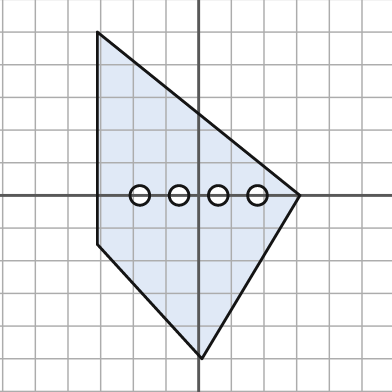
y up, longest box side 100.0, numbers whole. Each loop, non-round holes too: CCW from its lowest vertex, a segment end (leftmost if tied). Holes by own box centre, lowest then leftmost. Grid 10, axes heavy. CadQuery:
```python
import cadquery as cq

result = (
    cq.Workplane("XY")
    .moveTo(1.0, -50.0)
    .lineTo(31.0, 0.0)
    .lineTo(-31.0, 50.0)
    .lineTo(-31.0, -15.0)
    .close()
    .moveTo(-18.0, 0.0)
    .circle(3.0)
    .moveTo(-6.0, 0.0)
    .circle(3.0)
    .moveTo(6.0, 0.0)
    .circle(3.0)
    .moveTo(18.0, 0.0)
    .circle(3.0)
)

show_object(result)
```